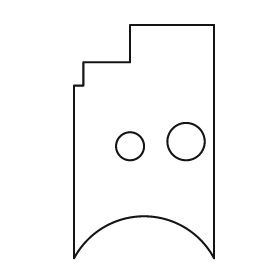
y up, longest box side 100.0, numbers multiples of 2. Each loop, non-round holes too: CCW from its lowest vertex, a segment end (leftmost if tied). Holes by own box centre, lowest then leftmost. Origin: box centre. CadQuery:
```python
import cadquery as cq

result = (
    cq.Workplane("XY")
    .moveTo(-30.0, -50.0)
    .threePointArc((0.0, -32.0), (30.0, -50.0))
    .lineTo(30.0, 50.0)
    .lineTo(-6.0, 50.0)
    .lineTo(-6.0, 34.0)
    .lineTo(-26.0, 34.0)
    .lineTo(-26.0, 24.0)
    .lineTo(-30.0, 24.0)
    .close()
    .moveTo(-6.0, -2.0)
    .circle(6.0)
    .moveTo(18.0, 0.0)
    .circle(8.0)
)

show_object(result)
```